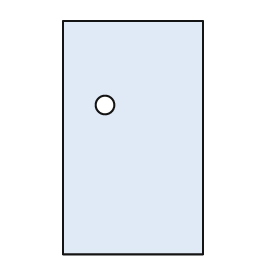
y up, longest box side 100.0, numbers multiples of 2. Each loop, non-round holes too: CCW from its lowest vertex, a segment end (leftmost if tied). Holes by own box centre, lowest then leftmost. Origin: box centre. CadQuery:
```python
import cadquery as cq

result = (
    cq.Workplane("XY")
    .moveTo(-30.0, -50.0)
    .lineTo(30.0, -50.0)
    .lineTo(30.0, 50.0)
    .lineTo(-30.0, 50.0)
    .close()
    .moveTo(-12.0, 14.0)
    .circle(4.0)
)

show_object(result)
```